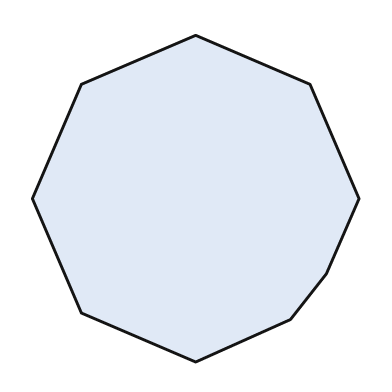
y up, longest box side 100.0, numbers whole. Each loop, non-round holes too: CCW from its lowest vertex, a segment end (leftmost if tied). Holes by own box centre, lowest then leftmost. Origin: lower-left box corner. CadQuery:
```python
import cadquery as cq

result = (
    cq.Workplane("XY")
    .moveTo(50.0, 0.0)
    .lineTo(79.0, 13.0)
    .lineTo(90.0, 27.0)
    .lineTo(100.0, 50.0)
    .lineTo(85.0, 85.0)
    .lineTo(50.0, 100.0)
    .lineTo(15.0, 85.0)
    .lineTo(0.0, 50.0)
    .lineTo(15.0, 15.0)
    .close()
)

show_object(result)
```